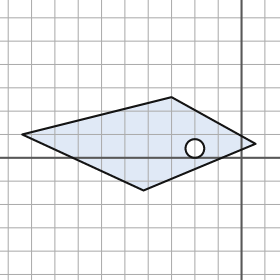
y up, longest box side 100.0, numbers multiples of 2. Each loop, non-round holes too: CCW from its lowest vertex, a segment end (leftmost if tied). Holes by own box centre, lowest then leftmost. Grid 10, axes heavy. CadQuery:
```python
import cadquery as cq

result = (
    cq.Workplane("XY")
    .moveTo(-42.0, -14.0)
    .lineTo(6.0, 6.0)
    .lineTo(-30.0, 26.0)
    .lineTo(-94.0, 10.0)
    .close()
    .moveTo(-20.0, 4.0)
    .circle(4.0)
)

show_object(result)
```